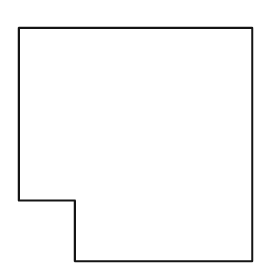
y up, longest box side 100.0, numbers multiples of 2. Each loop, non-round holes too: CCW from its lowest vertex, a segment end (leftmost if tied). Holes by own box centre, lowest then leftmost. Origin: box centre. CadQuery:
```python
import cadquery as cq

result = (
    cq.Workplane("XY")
    .moveTo(-26.0, -50.0)
    .lineTo(50.0, -50.0)
    .lineTo(50.0, 50.0)
    .lineTo(-50.0, 50.0)
    .lineTo(-50.0, -24.0)
    .lineTo(-26.0, -24.0)
    .close()
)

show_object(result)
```